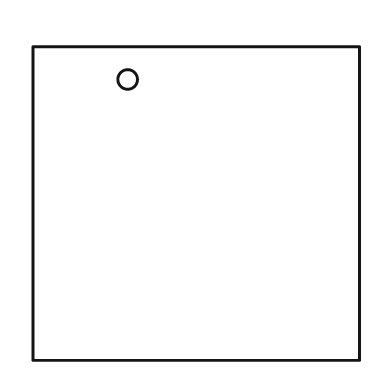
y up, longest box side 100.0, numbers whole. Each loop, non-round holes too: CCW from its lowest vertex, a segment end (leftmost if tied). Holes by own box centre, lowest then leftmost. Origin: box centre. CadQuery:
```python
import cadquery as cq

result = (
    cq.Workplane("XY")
    .moveTo(-50.0, -48.0)
    .lineTo(50.0, -48.0)
    .lineTo(50.0, 48.0)
    .lineTo(-50.0, 48.0)
    .close()
    .moveTo(-21.0, 38.0)
    .circle(3.0)
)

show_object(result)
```